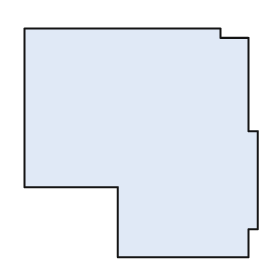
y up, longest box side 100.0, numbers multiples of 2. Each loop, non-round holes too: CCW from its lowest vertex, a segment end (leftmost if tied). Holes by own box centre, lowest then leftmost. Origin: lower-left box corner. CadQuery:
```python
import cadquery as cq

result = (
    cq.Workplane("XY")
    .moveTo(40.0, 0.0)
    .lineTo(96.0, 0.0)
    .lineTo(96.0, 12.0)
    .lineTo(100.0, 12.0)
    .lineTo(100.0, 54.0)
    .lineTo(96.0, 54.0)
    .lineTo(96.0, 94.0)
    .lineTo(84.0, 94.0)
    .lineTo(84.0, 98.0)
    .lineTo(0.0, 98.0)
    .lineTo(0.0, 30.0)
    .lineTo(40.0, 30.0)
    .close()
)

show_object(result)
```